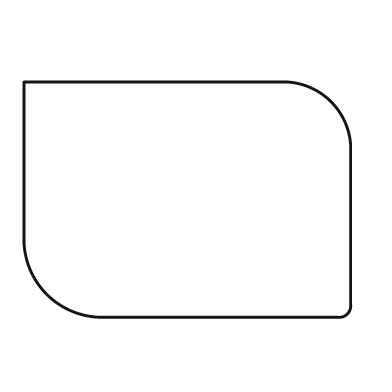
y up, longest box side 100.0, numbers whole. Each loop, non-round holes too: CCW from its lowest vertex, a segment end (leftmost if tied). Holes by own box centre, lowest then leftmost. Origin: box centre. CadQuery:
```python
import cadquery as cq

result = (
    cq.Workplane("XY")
    .moveTo(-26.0, -36.0)
    .lineTo(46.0, -36.0)
    .threePointArc((49.0, -35.0), (50.0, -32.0))
    .lineTo(50.0, 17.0)
    .threePointArc((44.0, 30.0), (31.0, 36.0))
    .lineTo(-50.0, 36.0)
    .lineTo(-50.0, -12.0)
    .threePointArc((-43.0, -29.0), (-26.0, -36.0))
    .close()
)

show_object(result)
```